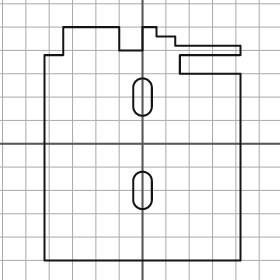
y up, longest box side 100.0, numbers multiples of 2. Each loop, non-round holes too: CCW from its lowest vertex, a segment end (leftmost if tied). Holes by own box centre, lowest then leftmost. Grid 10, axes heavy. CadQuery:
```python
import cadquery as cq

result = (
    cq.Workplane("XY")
    .moveTo(-42.0, -50.0)
    .lineTo(42.0, -50.0)
    .lineTo(42.0, 30.0)
    .lineTo(16.0, 30.0)
    .lineTo(16.0, 38.0)
    .lineTo(42.0, 38.0)
    .lineTo(42.0, 42.0)
    .lineTo(14.0, 42.0)
    .lineTo(14.0, 46.0)
    .lineTo(6.0, 46.0)
    .lineTo(6.0, 50.0)
    .lineTo(0.0, 50.0)
    .lineTo(0.0, 40.0)
    .lineTo(-10.0, 40.0)
    .lineTo(-10.0, 50.0)
    .lineTo(-34.0, 50.0)
    .lineTo(-34.0, 38.0)
    .lineTo(-42.0, 38.0)
    .close()
    .moveTo(-4.0, -24.0)
    .threePointArc((0.0, -28.0), (4.0, -24.0))
    .lineTo(4.0, -16.0)
    .threePointArc((0.0, -12.0), (-4.0, -16.0))
    .close()
    .moveTo(-4.0, 16.0)
    .threePointArc((0.0, 12.0), (4.0, 16.0))
    .lineTo(4.0, 24.0)
    .threePointArc((0.0, 28.0), (-4.0, 24.0))
    .close()
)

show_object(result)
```